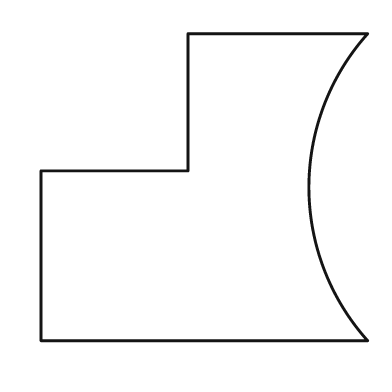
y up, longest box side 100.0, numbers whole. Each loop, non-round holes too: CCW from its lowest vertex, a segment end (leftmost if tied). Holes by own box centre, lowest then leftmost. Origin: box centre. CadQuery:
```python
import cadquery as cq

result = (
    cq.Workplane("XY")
    .moveTo(-50.0, -47.0)
    .lineTo(50.0, -47.0)
    .threePointArc((32.0, 0.0), (50.0, 47.0))
    .lineTo(-5.0, 47.0)
    .lineTo(-5.0, 5.0)
    .lineTo(-50.0, 5.0)
    .close()
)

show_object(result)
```